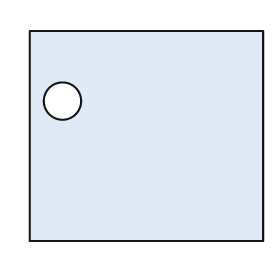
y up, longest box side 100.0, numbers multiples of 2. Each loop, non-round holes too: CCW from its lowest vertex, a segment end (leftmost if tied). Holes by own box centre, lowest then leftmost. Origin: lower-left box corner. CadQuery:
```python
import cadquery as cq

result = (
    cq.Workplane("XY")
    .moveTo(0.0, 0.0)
    .lineTo(100.0, 0.0)
    .lineTo(100.0, 90.0)
    .lineTo(0.0, 90.0)
    .close()
    .moveTo(14.0, 60.0)
    .circle(8.0)
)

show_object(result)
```